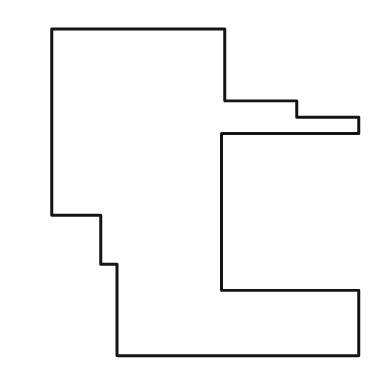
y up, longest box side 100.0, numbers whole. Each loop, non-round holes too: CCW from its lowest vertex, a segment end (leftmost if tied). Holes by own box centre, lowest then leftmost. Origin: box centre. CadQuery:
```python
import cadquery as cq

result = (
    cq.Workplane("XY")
    .moveTo(-27.0, -50.0)
    .lineTo(47.0, -50.0)
    .lineTo(47.0, -30.0)
    .lineTo(5.0, -30.0)
    .lineTo(5.0, 18.0)
    .lineTo(47.0, 18.0)
    .lineTo(47.0, 23.0)
    .lineTo(28.0, 23.0)
    .lineTo(28.0, 28.0)
    .lineTo(6.0, 28.0)
    .lineTo(6.0, 50.0)
    .lineTo(-47.0, 50.0)
    .lineTo(-47.0, -7.0)
    .lineTo(-32.0, -7.0)
    .lineTo(-32.0, -22.0)
    .lineTo(-27.0, -22.0)
    .close()
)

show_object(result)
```